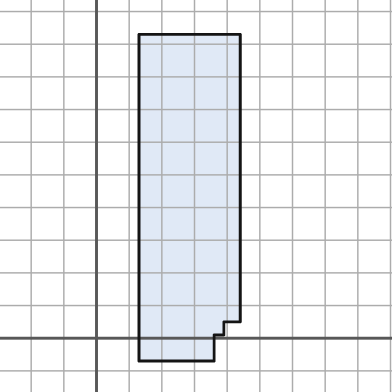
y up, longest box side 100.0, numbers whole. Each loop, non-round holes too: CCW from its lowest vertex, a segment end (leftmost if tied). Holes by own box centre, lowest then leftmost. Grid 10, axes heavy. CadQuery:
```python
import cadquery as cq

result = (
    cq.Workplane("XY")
    .moveTo(13.0, -7.0)
    .lineTo(36.0, -7.0)
    .lineTo(36.0, 1.0)
    .lineTo(39.0, 1.0)
    .lineTo(39.0, 5.0)
    .lineTo(44.0, 5.0)
    .lineTo(44.0, 93.0)
    .lineTo(13.0, 93.0)
    .close()
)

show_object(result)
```